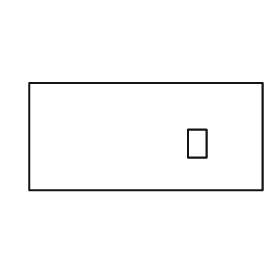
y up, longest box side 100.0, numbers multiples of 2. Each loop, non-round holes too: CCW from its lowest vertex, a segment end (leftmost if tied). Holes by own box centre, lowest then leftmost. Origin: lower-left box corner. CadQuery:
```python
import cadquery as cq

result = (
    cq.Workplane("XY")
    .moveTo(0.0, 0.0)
    .lineTo(100.0, 0.0)
    .lineTo(100.0, 46.0)
    .lineTo(0.0, 46.0)
    .close()
    .moveTo(68.0, 14.0)
    .lineTo(76.0, 14.0)
    .lineTo(76.0, 26.0)
    .lineTo(68.0, 26.0)
    .close()
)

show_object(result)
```